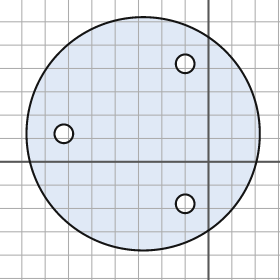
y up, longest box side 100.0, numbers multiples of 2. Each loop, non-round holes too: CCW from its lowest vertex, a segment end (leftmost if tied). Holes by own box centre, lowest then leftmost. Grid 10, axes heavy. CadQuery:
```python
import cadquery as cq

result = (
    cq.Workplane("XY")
    .moveTo(-28.0, 12.0)
    .circle(50.0)
    .moveTo(-10.0, -18.0)
    .circle(4.0)
    .moveTo(-62.0, 12.0)
    .circle(4.0)
    .moveTo(-10.0, 42.0)
    .circle(4.0)
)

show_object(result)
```